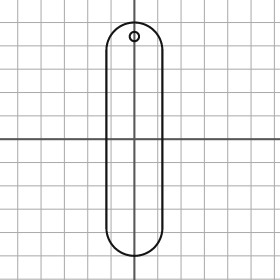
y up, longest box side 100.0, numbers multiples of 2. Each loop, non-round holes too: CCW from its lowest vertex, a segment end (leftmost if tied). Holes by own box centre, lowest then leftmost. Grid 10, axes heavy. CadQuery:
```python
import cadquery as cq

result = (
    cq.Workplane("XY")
    .moveTo(-12.0, -38.0)
    .threePointArc((0.0, -50.0), (12.0, -38.0))
    .lineTo(12.0, 38.0)
    .threePointArc((0.0, 50.0), (-12.0, 38.0))
    .close()
    .moveTo(0.0, 44.0)
    .circle(2.0)
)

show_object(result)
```